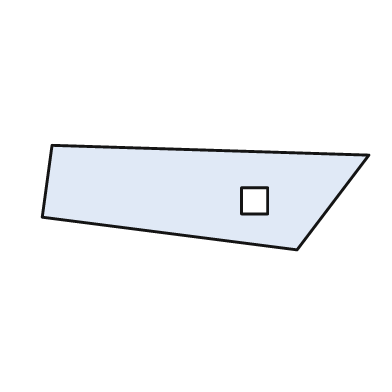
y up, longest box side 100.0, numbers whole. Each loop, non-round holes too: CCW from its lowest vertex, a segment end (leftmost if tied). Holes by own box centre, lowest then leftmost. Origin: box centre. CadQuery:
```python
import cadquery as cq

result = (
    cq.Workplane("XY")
    .moveTo(28.0, -16.0)
    .lineTo(50.0, 13.0)
    .lineTo(-47.0, 16.0)
    .lineTo(-50.0, -6.0)
    .close()
    .moveTo(11.0, -5.0)
    .lineTo(19.0, -5.0)
    .lineTo(19.0, 3.0)
    .lineTo(11.0, 3.0)
    .close()
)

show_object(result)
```